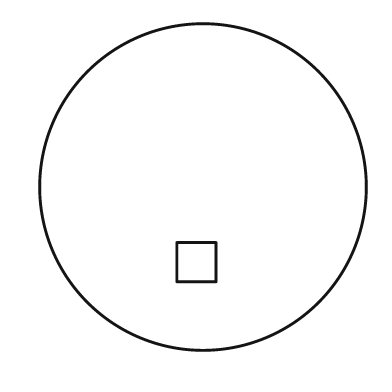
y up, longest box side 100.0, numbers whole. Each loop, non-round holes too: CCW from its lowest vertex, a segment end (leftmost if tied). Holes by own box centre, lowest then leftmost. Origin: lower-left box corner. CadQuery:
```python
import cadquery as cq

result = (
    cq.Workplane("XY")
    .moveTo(50.0, 50.0)
    .circle(50.0)
    .moveTo(42.0, 21.0)
    .lineTo(54.0, 21.0)
    .lineTo(54.0, 33.0)
    .lineTo(42.0, 33.0)
    .close()
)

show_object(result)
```